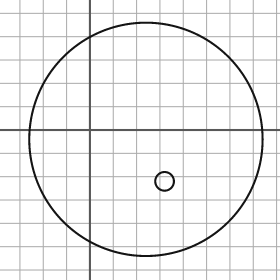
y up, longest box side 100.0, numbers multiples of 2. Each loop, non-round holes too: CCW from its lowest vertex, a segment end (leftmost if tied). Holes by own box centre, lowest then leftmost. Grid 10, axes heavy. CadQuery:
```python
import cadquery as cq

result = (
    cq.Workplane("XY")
    .moveTo(24.0, -4.0)
    .circle(50.0)
    .moveTo(32.0, -22.0)
    .circle(4.0)
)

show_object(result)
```